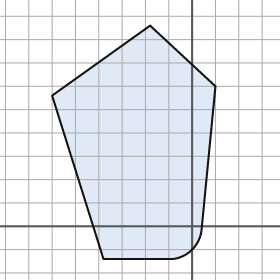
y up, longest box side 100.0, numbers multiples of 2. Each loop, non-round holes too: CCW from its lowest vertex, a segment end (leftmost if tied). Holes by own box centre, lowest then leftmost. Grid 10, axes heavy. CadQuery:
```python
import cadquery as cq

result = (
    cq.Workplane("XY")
    .moveTo(-38.0, -14.0)
    .lineTo(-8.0, -14.0)
    .threePointArc((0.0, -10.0), (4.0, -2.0))
    .lineTo(10.0, 60.0)
    .lineTo(-18.0, 86.0)
    .lineTo(-60.0, 56.0)
    .close()
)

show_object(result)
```